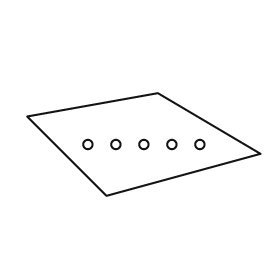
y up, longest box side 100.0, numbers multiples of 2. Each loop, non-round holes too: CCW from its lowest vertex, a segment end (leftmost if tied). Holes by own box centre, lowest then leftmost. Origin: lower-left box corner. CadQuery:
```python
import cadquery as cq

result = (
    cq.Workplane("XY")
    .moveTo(34.0, 0.0)
    .lineTo(100.0, 18.0)
    .lineTo(56.0, 44.0)
    .lineTo(0.0, 34.0)
    .close()
    .moveTo(26.0, 22.0)
    .circle(2.0)
    .moveTo(38.0, 22.0)
    .circle(2.0)
    .moveTo(50.0, 22.0)
    .circle(2.0)
    .moveTo(62.0, 22.0)
    .circle(2.0)
    .moveTo(74.0, 22.0)
    .circle(2.0)
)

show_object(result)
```